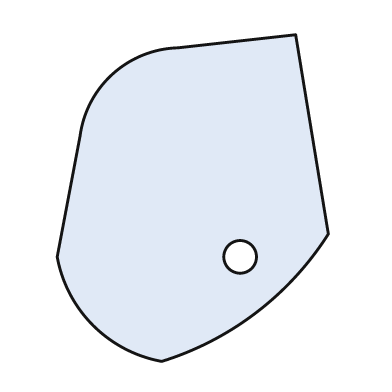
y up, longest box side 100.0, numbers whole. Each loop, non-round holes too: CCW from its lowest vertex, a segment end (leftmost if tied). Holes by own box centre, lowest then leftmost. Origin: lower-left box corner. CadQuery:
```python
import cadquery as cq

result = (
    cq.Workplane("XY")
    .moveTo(32.0, 0.0)
    .threePointArc((61.0, 15.0), (83.0, 39.0))
    .lineTo(73.0, 100.0)
    .lineTo(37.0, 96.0)
    .threePointArc((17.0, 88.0), (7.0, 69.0))
    .lineTo(0.0, 32.0)
    .threePointArc((11.0, 11.0), (32.0, 0.0))
    .close()
    .moveTo(56.0, 32.0)
    .circle(5.0)
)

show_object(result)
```